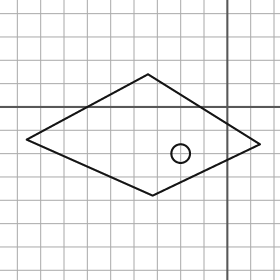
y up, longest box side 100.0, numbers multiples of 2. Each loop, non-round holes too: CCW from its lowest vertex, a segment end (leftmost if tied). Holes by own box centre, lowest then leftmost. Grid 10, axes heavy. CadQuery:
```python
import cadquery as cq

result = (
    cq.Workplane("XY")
    .moveTo(-32.0, -38.0)
    .lineTo(14.0, -16.0)
    .lineTo(-34.0, 14.0)
    .lineTo(-86.0, -14.0)
    .close()
    .moveTo(-20.0, -20.0)
    .circle(4.0)
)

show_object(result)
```